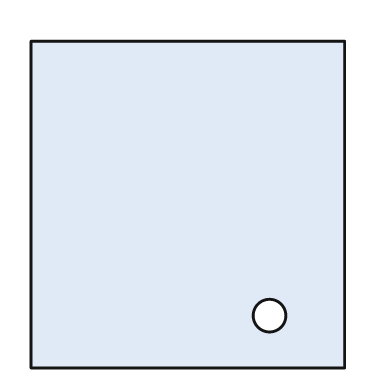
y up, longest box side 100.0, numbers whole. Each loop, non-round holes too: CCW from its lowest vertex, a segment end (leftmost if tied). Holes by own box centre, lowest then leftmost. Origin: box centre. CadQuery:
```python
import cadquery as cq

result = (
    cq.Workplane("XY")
    .moveTo(-48.0, -50.0)
    .lineTo(48.0, -50.0)
    .lineTo(48.0, 50.0)
    .lineTo(-48.0, 50.0)
    .close()
    .moveTo(25.0, -34.0)
    .circle(5.0)
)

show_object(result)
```